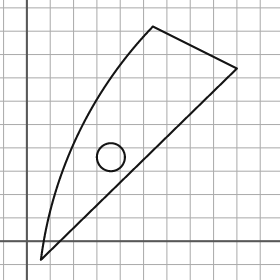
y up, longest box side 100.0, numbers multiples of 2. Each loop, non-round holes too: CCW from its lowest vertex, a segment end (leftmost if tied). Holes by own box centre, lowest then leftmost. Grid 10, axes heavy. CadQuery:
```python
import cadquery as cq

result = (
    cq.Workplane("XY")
    .moveTo(6.0, -8.0)
    .lineTo(90.0, 74.0)
    .lineTo(54.0, 92.0)
    .threePointArc((22.0, 46.0), (6.0, -8.0))
    .close()
    .moveTo(36.0, 36.0)
    .circle(6.0)
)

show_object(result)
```